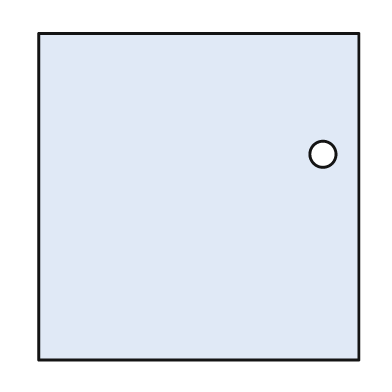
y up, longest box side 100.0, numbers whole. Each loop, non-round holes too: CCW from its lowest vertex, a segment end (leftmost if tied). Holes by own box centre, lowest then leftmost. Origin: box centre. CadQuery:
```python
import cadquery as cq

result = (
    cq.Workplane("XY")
    .moveTo(-49.0, -50.0)
    .lineTo(49.0, -50.0)
    .lineTo(49.0, 50.0)
    .lineTo(-49.0, 50.0)
    .close()
    .moveTo(38.0, 13.0)
    .circle(4.0)
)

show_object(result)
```